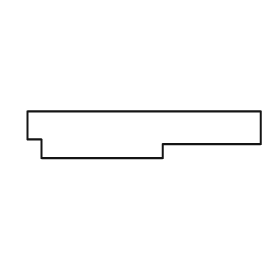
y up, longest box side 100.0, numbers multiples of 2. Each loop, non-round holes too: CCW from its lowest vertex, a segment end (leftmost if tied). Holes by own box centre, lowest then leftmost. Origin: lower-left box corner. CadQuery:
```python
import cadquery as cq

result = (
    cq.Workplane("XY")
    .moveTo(6.0, 0.0)
    .lineTo(58.0, 0.0)
    .lineTo(58.0, 6.0)
    .lineTo(100.0, 6.0)
    .lineTo(100.0, 20.0)
    .lineTo(0.0, 20.0)
    .lineTo(0.0, 8.0)
    .lineTo(6.0, 8.0)
    .close()
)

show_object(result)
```